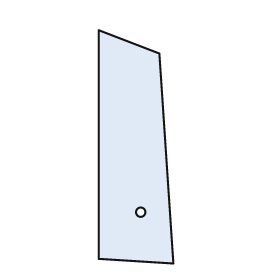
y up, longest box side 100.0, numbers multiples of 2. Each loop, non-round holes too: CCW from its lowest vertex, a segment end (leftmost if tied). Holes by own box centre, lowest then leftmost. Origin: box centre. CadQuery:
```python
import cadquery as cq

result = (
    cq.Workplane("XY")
    .moveTo(16.0, -50.0)
    .lineTo(10.0, 40.0)
    .lineTo(-16.0, 50.0)
    .lineTo(-16.0, -48.0)
    .close()
    .moveTo(2.0, -28.0)
    .circle(2.0)
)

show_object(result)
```